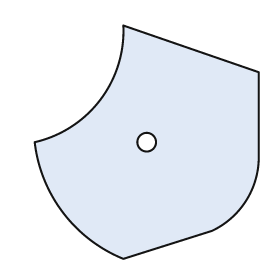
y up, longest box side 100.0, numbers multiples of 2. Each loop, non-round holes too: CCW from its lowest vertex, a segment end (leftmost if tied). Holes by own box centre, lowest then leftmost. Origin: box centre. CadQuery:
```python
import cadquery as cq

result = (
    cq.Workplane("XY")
    .moveTo(-10.0, -50.0)
    .lineTo(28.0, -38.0)
    .threePointArc((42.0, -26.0), (48.0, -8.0))
    .lineTo(48.0, 30.0)
    .lineTo(-10.0, 50.0)
    .threePointArc((-20.0, 18.0), (-48.0, 0.0))
    .threePointArc((-36.0, -30.0), (-10.0, -50.0))
    .close()
    .moveTo(0.0, 0.0)
    .circle(4.0)
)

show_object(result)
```